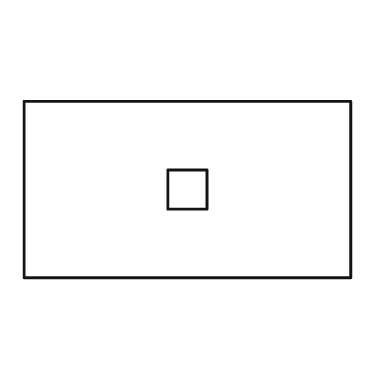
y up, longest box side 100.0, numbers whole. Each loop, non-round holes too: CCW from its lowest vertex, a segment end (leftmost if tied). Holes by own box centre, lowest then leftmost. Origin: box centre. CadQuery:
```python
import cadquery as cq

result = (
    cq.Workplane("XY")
    .moveTo(-50.0, -27.0)
    .lineTo(50.0, -27.0)
    .lineTo(50.0, 27.0)
    .lineTo(-50.0, 27.0)
    .close()
    .moveTo(-6.0, -6.0)
    .lineTo(6.0, -6.0)
    .lineTo(6.0, 6.0)
    .lineTo(-6.0, 6.0)
    .close()
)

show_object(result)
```